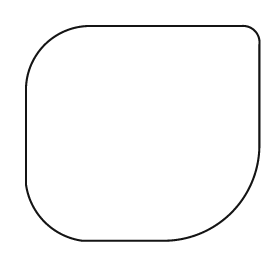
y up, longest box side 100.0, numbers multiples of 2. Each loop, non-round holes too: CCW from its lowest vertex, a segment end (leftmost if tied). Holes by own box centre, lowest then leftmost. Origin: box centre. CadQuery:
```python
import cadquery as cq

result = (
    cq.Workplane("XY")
    .moveTo(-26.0, -46.0)
    .lineTo(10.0, -46.0)
    .threePointArc((38.0, -34.0), (50.0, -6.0))
    .lineTo(50.0, 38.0)
    .threePointArc((48.0, 44.0), (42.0, 46.0))
    .lineTo(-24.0, 46.0)
    .threePointArc((-42.0, 38.0), (-50.0, 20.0))
    .lineTo(-50.0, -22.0)
    .threePointArc((-42.0, -38.0), (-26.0, -46.0))
    .close()
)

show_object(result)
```